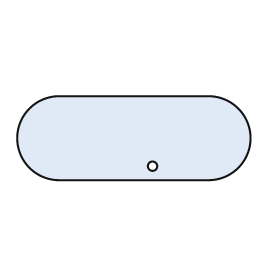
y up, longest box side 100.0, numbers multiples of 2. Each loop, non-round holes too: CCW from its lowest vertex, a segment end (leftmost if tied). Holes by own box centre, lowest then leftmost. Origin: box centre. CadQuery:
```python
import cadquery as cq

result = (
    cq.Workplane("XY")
    .moveTo(-32.0, -18.0)
    .lineTo(32.0, -18.0)
    .threePointArc((50.0, 0.0), (32.0, 18.0))
    .lineTo(-32.0, 18.0)
    .threePointArc((-50.0, 0.0), (-32.0, -18.0))
    .close()
    .moveTo(8.0, -12.0)
    .circle(2.0)
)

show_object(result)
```